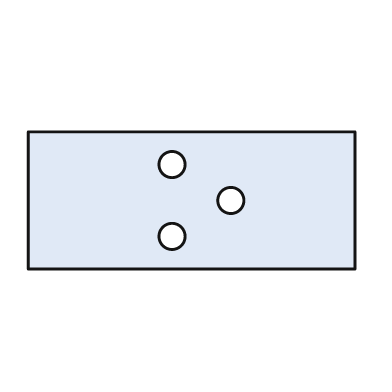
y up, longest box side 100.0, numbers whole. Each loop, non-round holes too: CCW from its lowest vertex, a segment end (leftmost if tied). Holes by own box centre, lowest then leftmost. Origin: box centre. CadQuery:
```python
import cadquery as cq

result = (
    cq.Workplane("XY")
    .moveTo(-50.0, -21.0)
    .lineTo(50.0, -21.0)
    .lineTo(50.0, 21.0)
    .lineTo(-50.0, 21.0)
    .close()
    .moveTo(-6.0, -11.0)
    .circle(4.0)
    .moveTo(12.0, 0.0)
    .circle(4.0)
    .moveTo(-6.0, 11.0)
    .circle(4.0)
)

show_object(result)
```